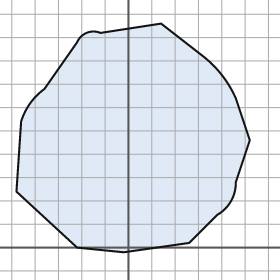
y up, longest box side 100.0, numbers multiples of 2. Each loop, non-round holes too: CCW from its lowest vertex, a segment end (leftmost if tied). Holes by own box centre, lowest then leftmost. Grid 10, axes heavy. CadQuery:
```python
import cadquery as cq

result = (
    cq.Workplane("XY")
    .moveTo(-2.0, -2.0)
    .lineTo(26.0, 2.0)
    .lineTo(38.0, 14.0)
    .threePointArc((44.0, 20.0), (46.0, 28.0))
    .lineTo(52.0, 46.0)
    .lineTo(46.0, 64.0)
    .threePointArc((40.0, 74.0), (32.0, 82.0))
    .lineTo(14.0, 96.0)
    .lineTo(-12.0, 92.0)
    .threePointArc((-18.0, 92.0), (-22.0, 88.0))
    .lineTo(-36.0, 68.0)
    .threePointArc((-42.0, 62.0), (-46.0, 54.0))
    .lineTo(-48.0, 24.0)
    .lineTo(-22.0, 0.0)
    .close()
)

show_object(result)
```